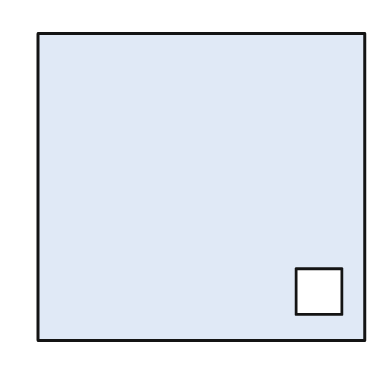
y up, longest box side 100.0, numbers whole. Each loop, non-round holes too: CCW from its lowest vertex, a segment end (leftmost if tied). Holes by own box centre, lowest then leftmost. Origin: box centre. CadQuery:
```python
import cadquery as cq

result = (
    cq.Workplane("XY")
    .moveTo(-50.0, -47.0)
    .lineTo(50.0, -47.0)
    .lineTo(50.0, 47.0)
    .lineTo(-50.0, 47.0)
    .close()
    .moveTo(29.0, -39.0)
    .lineTo(43.0, -39.0)
    .lineTo(43.0, -25.0)
    .lineTo(29.0, -25.0)
    .close()
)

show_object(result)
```